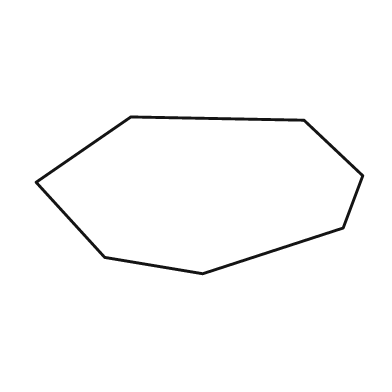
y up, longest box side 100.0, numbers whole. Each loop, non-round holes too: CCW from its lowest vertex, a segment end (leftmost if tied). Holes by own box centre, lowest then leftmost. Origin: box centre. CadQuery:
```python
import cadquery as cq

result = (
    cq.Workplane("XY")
    .moveTo(1.0, -24.0)
    .lineTo(44.0, -10.0)
    .lineTo(50.0, 6.0)
    .lineTo(32.0, 23.0)
    .lineTo(-21.0, 24.0)
    .lineTo(-50.0, 4.0)
    .lineTo(-29.0, -19.0)
    .close()
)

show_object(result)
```